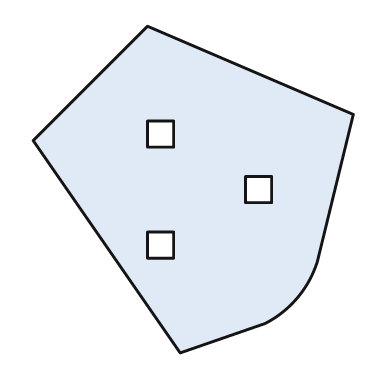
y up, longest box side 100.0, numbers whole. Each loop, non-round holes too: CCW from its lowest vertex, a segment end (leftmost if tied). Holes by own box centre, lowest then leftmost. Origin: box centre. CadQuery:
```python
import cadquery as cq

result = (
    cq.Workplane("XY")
    .moveTo(-4.0, -50.0)
    .lineTo(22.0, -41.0)
    .threePointArc((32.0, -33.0), (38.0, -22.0))
    .lineTo(49.0, 23.0)
    .lineTo(-14.0, 50.0)
    .lineTo(-49.0, 15.0)
    .close()
    .moveTo(-14.0, -21.0)
    .lineTo(-6.0, -21.0)
    .lineTo(-6.0, -13.0)
    .lineTo(-14.0, -13.0)
    .close()
    .moveTo(16.0, -4.0)
    .lineTo(24.0, -4.0)
    .lineTo(24.0, 4.0)
    .lineTo(16.0, 4.0)
    .close()
    .moveTo(-14.0, 13.0)
    .lineTo(-6.0, 13.0)
    .lineTo(-6.0, 21.0)
    .lineTo(-14.0, 21.0)
    .close()
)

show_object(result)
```